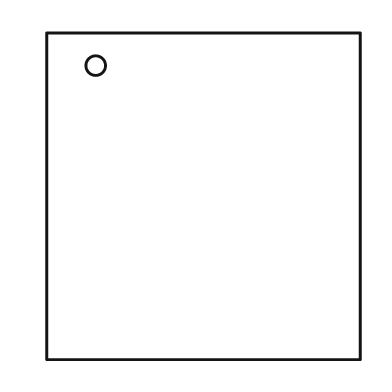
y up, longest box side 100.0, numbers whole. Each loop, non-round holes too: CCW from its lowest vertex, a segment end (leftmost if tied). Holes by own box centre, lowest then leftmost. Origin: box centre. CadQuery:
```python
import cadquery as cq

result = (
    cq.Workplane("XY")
    .moveTo(-48.0, -50.0)
    .lineTo(48.0, -50.0)
    .lineTo(48.0, 50.0)
    .lineTo(-48.0, 50.0)
    .close()
    .moveTo(-33.0, 40.0)
    .circle(3.0)
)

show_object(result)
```